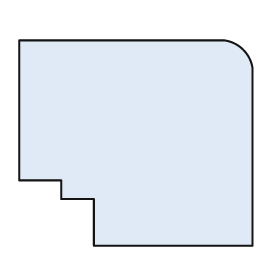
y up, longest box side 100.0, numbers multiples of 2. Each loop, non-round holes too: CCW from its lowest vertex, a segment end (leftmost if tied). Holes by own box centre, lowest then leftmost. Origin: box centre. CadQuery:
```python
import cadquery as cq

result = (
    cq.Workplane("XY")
    .moveTo(-18.0, -44.0)
    .lineTo(50.0, -44.0)
    .lineTo(50.0, 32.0)
    .threePointArc((46.0, 40.0), (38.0, 44.0))
    .lineTo(-50.0, 44.0)
    .lineTo(-50.0, -16.0)
    .lineTo(-32.0, -16.0)
    .lineTo(-32.0, -24.0)
    .lineTo(-18.0, -24.0)
    .close()
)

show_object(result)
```